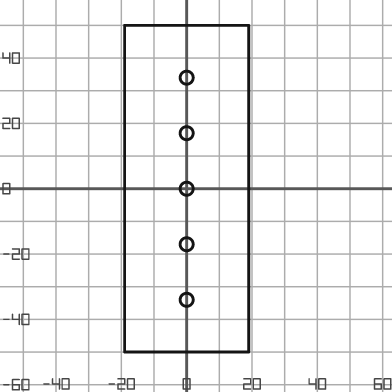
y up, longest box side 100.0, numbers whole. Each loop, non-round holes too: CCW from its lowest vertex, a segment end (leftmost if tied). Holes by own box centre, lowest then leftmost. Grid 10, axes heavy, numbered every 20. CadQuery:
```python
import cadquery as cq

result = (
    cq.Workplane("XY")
    .moveTo(-19.0, -50.0)
    .lineTo(19.0, -50.0)
    .lineTo(19.0, 50.0)
    .lineTo(-19.0, 50.0)
    .close()
    .moveTo(0.0, -34.0)
    .circle(2.0)
    .moveTo(0.0, -17.0)
    .circle(2.0)
    .moveTo(0.0, 0.0)
    .circle(2.0)
    .moveTo(0.0, 17.0)
    .circle(2.0)
    .moveTo(0.0, 34.0)
    .circle(2.0)
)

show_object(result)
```